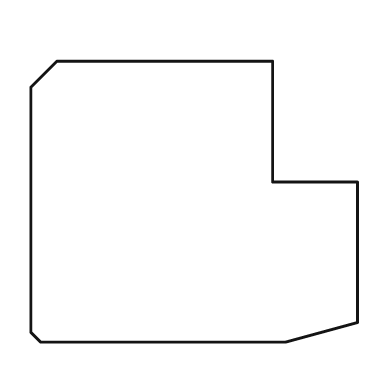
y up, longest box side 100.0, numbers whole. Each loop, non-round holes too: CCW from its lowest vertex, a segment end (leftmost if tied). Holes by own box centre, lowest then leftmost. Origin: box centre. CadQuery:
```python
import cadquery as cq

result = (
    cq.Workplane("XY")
    .moveTo(-47.0, -43.0)
    .lineTo(28.0, -43.0)
    .lineTo(50.0, -37.0)
    .lineTo(50.0, 6.0)
    .lineTo(24.0, 6.0)
    .lineTo(24.0, 43.0)
    .lineTo(-42.0, 43.0)
    .lineTo(-50.0, 35.0)
    .lineTo(-50.0, -40.0)
    .close()
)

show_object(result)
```